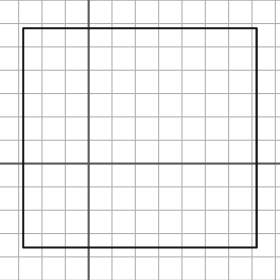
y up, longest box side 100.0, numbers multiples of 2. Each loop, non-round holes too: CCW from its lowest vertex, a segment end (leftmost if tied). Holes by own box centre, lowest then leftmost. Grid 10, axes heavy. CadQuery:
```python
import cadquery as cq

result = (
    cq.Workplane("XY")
    .moveTo(-28.0, -36.0)
    .lineTo(72.0, -36.0)
    .lineTo(72.0, 58.0)
    .lineTo(-28.0, 58.0)
    .close()
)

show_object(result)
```